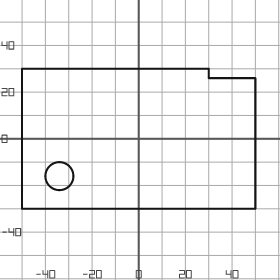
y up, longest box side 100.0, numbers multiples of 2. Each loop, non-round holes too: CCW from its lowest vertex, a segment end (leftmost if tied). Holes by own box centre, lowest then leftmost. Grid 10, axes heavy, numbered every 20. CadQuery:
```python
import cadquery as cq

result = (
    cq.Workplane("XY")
    .moveTo(-50.0, -30.0)
    .lineTo(50.0, -30.0)
    .lineTo(50.0, 26.0)
    .lineTo(30.0, 26.0)
    .lineTo(30.0, 30.0)
    .lineTo(-50.0, 30.0)
    .close()
    .moveTo(-34.0, -16.0)
    .circle(6.0)
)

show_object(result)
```